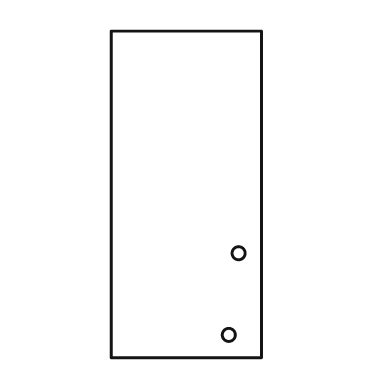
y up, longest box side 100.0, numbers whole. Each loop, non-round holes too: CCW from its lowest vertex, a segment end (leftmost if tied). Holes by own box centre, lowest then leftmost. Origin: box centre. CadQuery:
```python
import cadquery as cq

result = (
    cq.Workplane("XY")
    .moveTo(-23.0, -50.0)
    .lineTo(23.0, -50.0)
    .lineTo(23.0, 50.0)
    .lineTo(-23.0, 50.0)
    .close()
    .moveTo(13.0, -43.0)
    .circle(2.0)
    .moveTo(16.0, -18.0)
    .circle(2.0)
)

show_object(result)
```